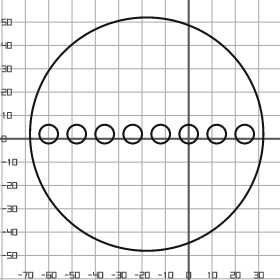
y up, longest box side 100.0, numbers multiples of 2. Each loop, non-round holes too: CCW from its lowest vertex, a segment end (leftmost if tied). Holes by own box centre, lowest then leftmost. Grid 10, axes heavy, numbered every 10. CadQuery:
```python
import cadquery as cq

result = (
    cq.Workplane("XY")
    .moveTo(-18.0, 2.0)
    .circle(50.0)
    .moveTo(-60.0, 2.0)
    .circle(4.0)
    .moveTo(-48.0, 2.0)
    .circle(4.0)
    .moveTo(-36.0, 2.0)
    .circle(4.0)
    .moveTo(-24.0, 2.0)
    .circle(4.0)
    .moveTo(-12.0, 2.0)
    .circle(4.0)
    .moveTo(0.0, 2.0)
    .circle(4.0)
    .moveTo(12.0, 2.0)
    .circle(4.0)
    .moveTo(24.0, 2.0)
    .circle(4.0)
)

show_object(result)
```